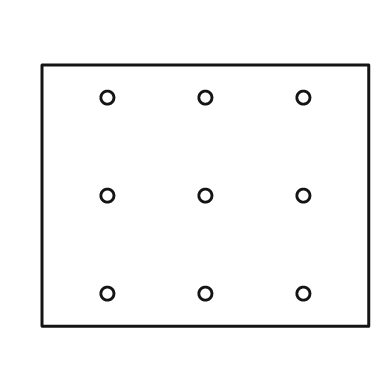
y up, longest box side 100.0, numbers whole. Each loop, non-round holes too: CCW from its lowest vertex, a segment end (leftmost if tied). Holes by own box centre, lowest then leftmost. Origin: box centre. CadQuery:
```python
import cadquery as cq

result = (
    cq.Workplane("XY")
    .moveTo(-50.0, -40.0)
    .lineTo(50.0, -40.0)
    .lineTo(50.0, 40.0)
    .lineTo(-50.0, 40.0)
    .close()
    .moveTo(-30.0, -30.0)
    .circle(2.0)
    .moveTo(0.0, -30.0)
    .circle(2.0)
    .moveTo(30.0, -30.0)
    .circle(2.0)
    .moveTo(-30.0, 0.0)
    .circle(2.0)
    .moveTo(0.0, 0.0)
    .circle(2.0)
    .moveTo(30.0, 0.0)
    .circle(2.0)
    .moveTo(-30.0, 30.0)
    .circle(2.0)
    .moveTo(0.0, 30.0)
    .circle(2.0)
    .moveTo(30.0, 30.0)
    .circle(2.0)
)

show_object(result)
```